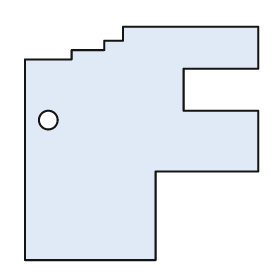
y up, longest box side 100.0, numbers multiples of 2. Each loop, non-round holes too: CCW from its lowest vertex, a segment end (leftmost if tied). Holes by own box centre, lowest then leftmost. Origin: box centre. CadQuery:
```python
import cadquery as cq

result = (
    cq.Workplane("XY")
    .moveTo(-50.0, -50.0)
    .lineTo(6.0, -50.0)
    .lineTo(6.0, -12.0)
    .lineTo(50.0, -12.0)
    .lineTo(50.0, 14.0)
    .lineTo(18.0, 14.0)
    .lineTo(18.0, 32.0)
    .lineTo(50.0, 32.0)
    .lineTo(50.0, 50.0)
    .lineTo(-8.0, 50.0)
    .lineTo(-8.0, 44.0)
    .lineTo(-16.0, 44.0)
    .lineTo(-16.0, 40.0)
    .lineTo(-30.0, 40.0)
    .lineTo(-30.0, 36.0)
    .lineTo(-50.0, 36.0)
    .close()
    .moveTo(-40.0, 10.0)
    .circle(4.0)
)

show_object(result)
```